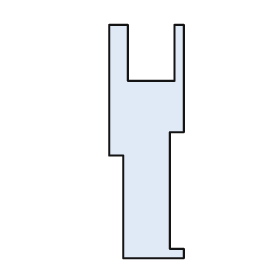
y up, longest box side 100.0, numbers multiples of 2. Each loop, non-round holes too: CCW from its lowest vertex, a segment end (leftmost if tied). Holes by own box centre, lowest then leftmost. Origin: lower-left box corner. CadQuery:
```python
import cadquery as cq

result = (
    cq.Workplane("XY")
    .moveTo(6.0, 0.0)
    .lineTo(32.0, 0.0)
    .lineTo(32.0, 4.0)
    .lineTo(26.0, 4.0)
    .lineTo(26.0, 54.0)
    .lineTo(32.0, 54.0)
    .lineTo(32.0, 100.0)
    .lineTo(28.0, 100.0)
    .lineTo(28.0, 76.0)
    .lineTo(8.0, 76.0)
    .lineTo(8.0, 100.0)
    .lineTo(0.0, 100.0)
    .lineTo(0.0, 44.0)
    .lineTo(6.0, 44.0)
    .close()
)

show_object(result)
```